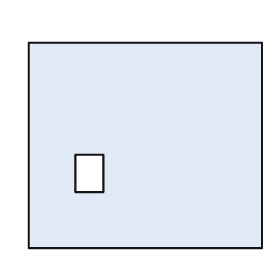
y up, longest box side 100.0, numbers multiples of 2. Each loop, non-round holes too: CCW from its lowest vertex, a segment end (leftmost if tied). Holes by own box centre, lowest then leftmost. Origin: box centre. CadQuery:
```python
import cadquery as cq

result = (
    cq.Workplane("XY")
    .moveTo(-50.0, -44.0)
    .lineTo(50.0, -44.0)
    .lineTo(50.0, 44.0)
    .lineTo(-50.0, 44.0)
    .close()
    .moveTo(-30.0, -20.0)
    .lineTo(-18.0, -20.0)
    .lineTo(-18.0, -4.0)
    .lineTo(-30.0, -4.0)
    .close()
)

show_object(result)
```